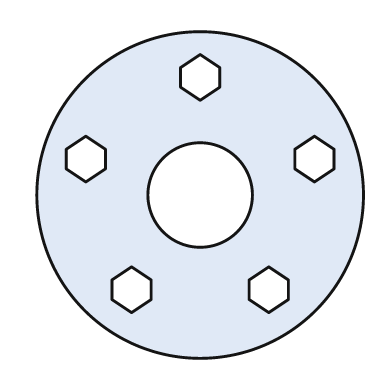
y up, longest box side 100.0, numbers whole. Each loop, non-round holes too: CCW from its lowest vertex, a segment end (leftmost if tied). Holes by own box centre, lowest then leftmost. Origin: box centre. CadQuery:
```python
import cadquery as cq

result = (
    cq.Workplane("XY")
    .moveTo(0.0, 0.0)
    .circle(50.0)
    .moveTo(-21.0, -36.0)
    .lineTo(-15.0, -32.0)
    .lineTo(-15.0, -26.0)
    .lineTo(-21.0, -22.0)
    .lineTo(-27.0, -26.0)
    .lineTo(-27.0, -32.0)
    .close()
    .moveTo(21.0, -36.0)
    .lineTo(27.0, -32.0)
    .lineTo(27.0, -26.0)
    .lineTo(21.0, -22.0)
    .lineTo(15.0, -26.0)
    .lineTo(15.0, -32.0)
    .close()
    .moveTo(0.0, 0.0)
    .circle(16.0)
    .moveTo(-35.0, 4.0)
    .lineTo(-29.0, 8.0)
    .lineTo(-29.0, 14.0)
    .lineTo(-35.0, 18.0)
    .lineTo(-41.0, 14.0)
    .lineTo(-41.0, 8.0)
    .close()
    .moveTo(35.0, 4.0)
    .lineTo(41.0, 8.0)
    .lineTo(41.0, 14.0)
    .lineTo(35.0, 18.0)
    .lineTo(29.0, 14.0)
    .lineTo(29.0, 8.0)
    .close()
    .moveTo(0.0, 29.0)
    .lineTo(6.0, 33.0)
    .lineTo(6.0, 39.0)
    .lineTo(0.0, 43.0)
    .lineTo(-6.0, 39.0)
    .lineTo(-6.0, 33.0)
    .close()
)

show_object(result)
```